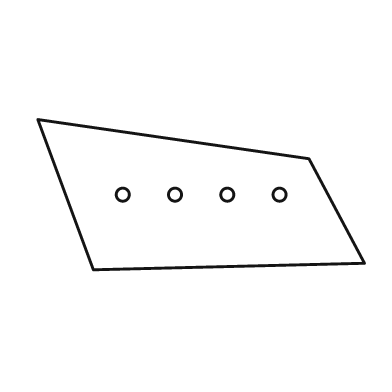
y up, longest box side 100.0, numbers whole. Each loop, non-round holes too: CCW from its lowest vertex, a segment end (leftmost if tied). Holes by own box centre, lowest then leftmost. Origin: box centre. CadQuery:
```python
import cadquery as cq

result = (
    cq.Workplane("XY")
    .moveTo(-33.0, -23.0)
    .lineTo(50.0, -21.0)
    .lineTo(33.0, 11.0)
    .lineTo(-50.0, 23.0)
    .close()
    .moveTo(-24.0, 0.0)
    .circle(2.0)
    .moveTo(-8.0, 0.0)
    .circle(2.0)
    .moveTo(8.0, 0.0)
    .circle(2.0)
    .moveTo(24.0, 0.0)
    .circle(2.0)
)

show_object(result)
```